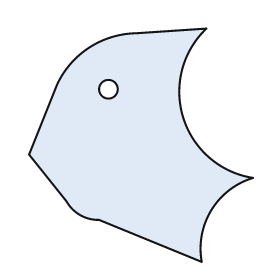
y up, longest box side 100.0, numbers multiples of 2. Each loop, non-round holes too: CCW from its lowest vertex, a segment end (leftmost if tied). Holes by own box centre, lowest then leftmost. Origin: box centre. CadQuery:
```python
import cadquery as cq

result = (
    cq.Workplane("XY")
    .moveTo(26.0, -50.0)
    .threePointArc((30.0, -28.0), (48.0, -14.0))
    .threePointArc((18.0, 12.0), (28.0, 50.0))
    .lineTo(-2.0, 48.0)
    .threePointArc((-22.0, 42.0), (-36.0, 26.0))
    .lineTo(-48.0, -4.0)
    .lineTo(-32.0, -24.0)
    .threePointArc((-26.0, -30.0), (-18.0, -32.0))
    .close()
    .moveTo(-14.0, 24.0)
    .circle(4.0)
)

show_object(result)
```